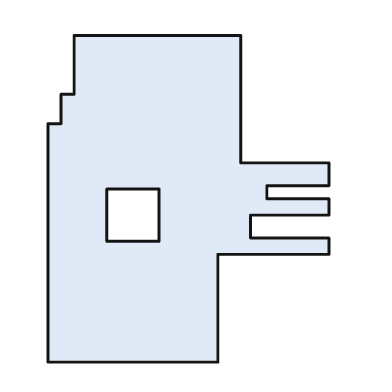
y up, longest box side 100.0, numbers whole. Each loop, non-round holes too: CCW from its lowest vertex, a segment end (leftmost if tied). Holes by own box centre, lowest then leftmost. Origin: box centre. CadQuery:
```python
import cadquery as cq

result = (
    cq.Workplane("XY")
    .moveTo(-43.0, -50.0)
    .lineTo(9.0, -50.0)
    .lineTo(9.0, -17.0)
    .lineTo(43.0, -17.0)
    .lineTo(43.0, -12.0)
    .lineTo(19.0, -12.0)
    .lineTo(19.0, -5.0)
    .lineTo(43.0, -5.0)
    .lineTo(43.0, 0.0)
    .lineTo(24.0, 0.0)
    .lineTo(24.0, 4.0)
    .lineTo(43.0, 4.0)
    .lineTo(43.0, 11.0)
    .lineTo(16.0, 11.0)
    .lineTo(16.0, 50.0)
    .lineTo(-35.0, 50.0)
    .lineTo(-35.0, 32.0)
    .lineTo(-39.0, 32.0)
    .lineTo(-39.0, 23.0)
    .lineTo(-43.0, 23.0)
    .close()
    .moveTo(-25.0, -13.0)
    .lineTo(-9.0, -13.0)
    .lineTo(-9.0, 3.0)
    .lineTo(-25.0, 3.0)
    .close()
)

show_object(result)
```